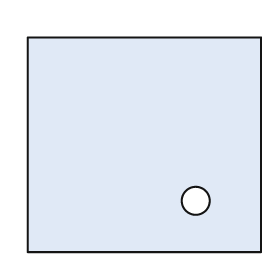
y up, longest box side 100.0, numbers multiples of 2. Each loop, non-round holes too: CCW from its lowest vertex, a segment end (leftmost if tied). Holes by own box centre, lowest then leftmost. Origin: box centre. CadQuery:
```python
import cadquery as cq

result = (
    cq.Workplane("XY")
    .moveTo(-50.0, -46.0)
    .lineTo(50.0, -46.0)
    .lineTo(50.0, 46.0)
    .lineTo(-50.0, 46.0)
    .close()
    .moveTo(22.0, -24.0)
    .circle(6.0)
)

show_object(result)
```